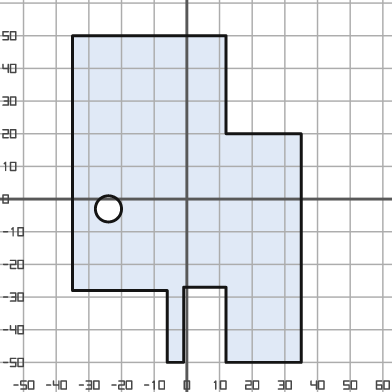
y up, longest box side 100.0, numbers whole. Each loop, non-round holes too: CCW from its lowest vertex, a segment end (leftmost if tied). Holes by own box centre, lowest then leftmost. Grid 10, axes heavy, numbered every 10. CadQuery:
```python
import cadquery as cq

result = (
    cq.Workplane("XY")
    .moveTo(-6.0, -50.0)
    .lineTo(-1.0, -50.0)
    .lineTo(-1.0, -27.0)
    .lineTo(12.0, -27.0)
    .lineTo(12.0, -50.0)
    .lineTo(35.0, -50.0)
    .lineTo(35.0, 20.0)
    .lineTo(12.0, 20.0)
    .lineTo(12.0, 50.0)
    .lineTo(-35.0, 50.0)
    .lineTo(-35.0, -28.0)
    .lineTo(-6.0, -28.0)
    .close()
    .moveTo(-24.0, -3.0)
    .circle(4.0)
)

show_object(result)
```